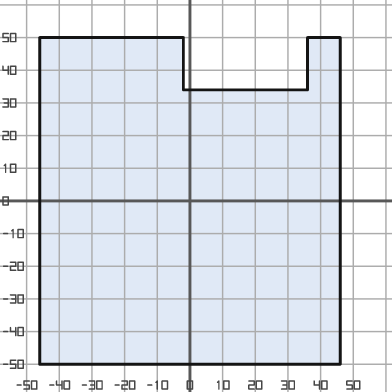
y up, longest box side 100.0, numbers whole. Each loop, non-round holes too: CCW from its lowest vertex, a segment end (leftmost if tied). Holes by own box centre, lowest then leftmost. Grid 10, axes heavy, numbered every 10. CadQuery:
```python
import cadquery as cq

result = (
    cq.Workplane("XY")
    .moveTo(-46.0, -50.0)
    .lineTo(46.0, -50.0)
    .lineTo(46.0, 50.0)
    .lineTo(36.0, 50.0)
    .lineTo(36.0, 34.0)
    .lineTo(-2.0, 34.0)
    .lineTo(-2.0, 50.0)
    .lineTo(-46.0, 50.0)
    .close()
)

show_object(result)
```